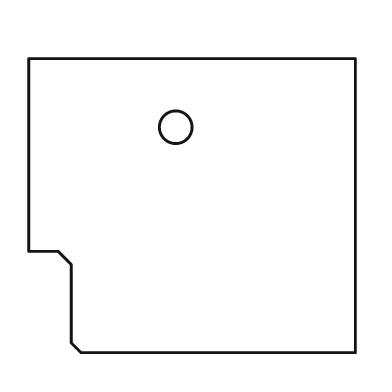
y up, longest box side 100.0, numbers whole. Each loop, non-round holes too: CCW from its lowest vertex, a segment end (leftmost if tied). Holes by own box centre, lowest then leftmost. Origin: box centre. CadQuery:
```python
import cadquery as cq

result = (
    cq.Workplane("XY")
    .moveTo(-34.0, -45.0)
    .lineTo(50.0, -45.0)
    .lineTo(50.0, 45.0)
    .lineTo(-50.0, 45.0)
    .lineTo(-50.0, -14.0)
    .lineTo(-41.0, -14.0)
    .lineTo(-37.0, -18.0)
    .lineTo(-37.0, -42.0)
    .close()
    .moveTo(-5.0, 24.0)
    .circle(5.0)
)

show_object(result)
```